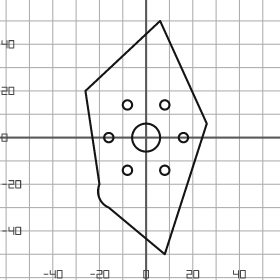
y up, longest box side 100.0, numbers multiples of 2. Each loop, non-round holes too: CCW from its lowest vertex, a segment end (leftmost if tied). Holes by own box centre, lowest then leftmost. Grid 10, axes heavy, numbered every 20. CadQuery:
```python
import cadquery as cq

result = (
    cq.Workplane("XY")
    .moveTo(8.0, -50.0)
    .lineTo(26.0, 6.0)
    .lineTo(6.0, 50.0)
    .lineTo(-26.0, 20.0)
    .lineTo(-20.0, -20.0)
    .threePointArc((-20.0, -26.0), (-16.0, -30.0))
    .close()
    .moveTo(-8.0, -14.0)
    .circle(2.0)
    .moveTo(8.0, -14.0)
    .circle(2.0)
    .moveTo(-16.0, 0.0)
    .circle(2.0)
    .moveTo(0.0, 0.0)
    .circle(6.0)
    .moveTo(16.0, 0.0)
    .circle(2.0)
    .moveTo(-8.0, 14.0)
    .circle(2.0)
    .moveTo(8.0, 14.0)
    .circle(2.0)
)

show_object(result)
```